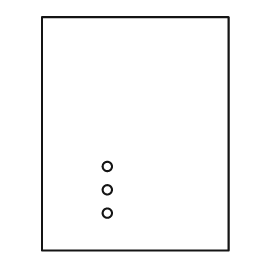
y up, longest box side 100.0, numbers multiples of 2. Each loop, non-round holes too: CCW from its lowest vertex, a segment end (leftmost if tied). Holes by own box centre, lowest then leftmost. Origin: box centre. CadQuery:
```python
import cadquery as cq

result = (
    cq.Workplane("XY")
    .moveTo(-40.0, -50.0)
    .lineTo(40.0, -50.0)
    .lineTo(40.0, 50.0)
    .lineTo(-40.0, 50.0)
    .close()
    .moveTo(-12.0, -34.0)
    .circle(2.0)
    .moveTo(-12.0, -24.0)
    .circle(2.0)
    .moveTo(-12.0, -14.0)
    .circle(2.0)
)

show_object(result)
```